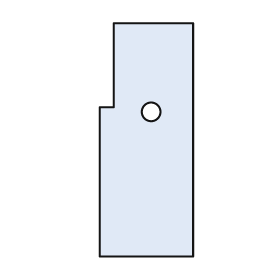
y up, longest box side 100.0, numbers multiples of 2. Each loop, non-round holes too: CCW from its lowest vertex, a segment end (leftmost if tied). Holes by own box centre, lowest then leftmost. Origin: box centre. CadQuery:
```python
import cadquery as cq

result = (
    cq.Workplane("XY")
    .moveTo(-20.0, -50.0)
    .lineTo(20.0, -50.0)
    .lineTo(20.0, 50.0)
    .lineTo(-14.0, 50.0)
    .lineTo(-14.0, 14.0)
    .lineTo(-20.0, 14.0)
    .close()
    .moveTo(2.0, 12.0)
    .circle(4.0)
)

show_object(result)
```